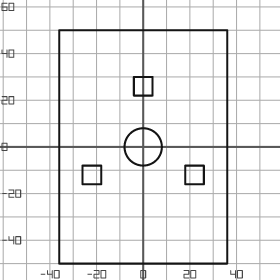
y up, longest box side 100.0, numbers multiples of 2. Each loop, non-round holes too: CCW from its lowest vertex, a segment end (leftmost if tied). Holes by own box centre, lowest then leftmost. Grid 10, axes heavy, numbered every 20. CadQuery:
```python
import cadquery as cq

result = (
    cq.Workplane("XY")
    .moveTo(-36.0, -50.0)
    .lineTo(36.0, -50.0)
    .lineTo(36.0, 50.0)
    .lineTo(-36.0, 50.0)
    .close()
    .moveTo(-26.0, -16.0)
    .lineTo(-18.0, -16.0)
    .lineTo(-18.0, -8.0)
    .lineTo(-26.0, -8.0)
    .close()
    .moveTo(18.0, -16.0)
    .lineTo(26.0, -16.0)
    .lineTo(26.0, -8.0)
    .lineTo(18.0, -8.0)
    .close()
    .moveTo(0.0, 0.0)
    .circle(8.0)
    .moveTo(-4.0, 22.0)
    .lineTo(4.0, 22.0)
    .lineTo(4.0, 30.0)
    .lineTo(-4.0, 30.0)
    .close()
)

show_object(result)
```